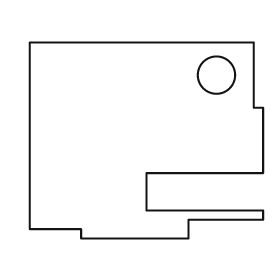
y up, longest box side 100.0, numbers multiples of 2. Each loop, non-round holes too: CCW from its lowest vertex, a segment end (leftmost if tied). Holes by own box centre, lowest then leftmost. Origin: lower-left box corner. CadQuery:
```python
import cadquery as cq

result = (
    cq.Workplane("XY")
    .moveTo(22.0, 0.0)
    .lineTo(68.0, 0.0)
    .lineTo(68.0, 8.0)
    .lineTo(100.0, 8.0)
    .lineTo(100.0, 12.0)
    .lineTo(50.0, 12.0)
    .lineTo(50.0, 28.0)
    .lineTo(100.0, 28.0)
    .lineTo(100.0, 56.0)
    .lineTo(96.0, 56.0)
    .lineTo(96.0, 84.0)
    .lineTo(0.0, 84.0)
    .lineTo(0.0, 4.0)
    .lineTo(22.0, 4.0)
    .close()
    .moveTo(80.0, 70.0)
    .circle(8.0)
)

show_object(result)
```